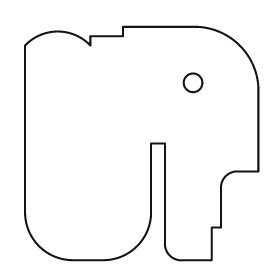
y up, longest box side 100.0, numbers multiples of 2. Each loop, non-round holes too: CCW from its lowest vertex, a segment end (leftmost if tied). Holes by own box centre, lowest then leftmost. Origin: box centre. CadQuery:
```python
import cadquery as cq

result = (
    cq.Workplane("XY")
    .moveTo(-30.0, -50.0)
    .lineTo(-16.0, -50.0)
    .threePointArc((-2.0, -44.0), (4.0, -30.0))
    .lineTo(4.0, 0.0)
    .lineTo(10.0, 0.0)
    .lineTo(10.0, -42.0)
    .threePointArc((12.0, -48.0), (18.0, -50.0))
    .lineTo(30.0, -50.0)
    .lineTo(30.0, -36.0)
    .lineTo(34.0, -36.0)
    .lineTo(34.0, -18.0)
    .threePointArc((36.0, -14.0), (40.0, -12.0))
    .lineTo(50.0, -12.0)
    .lineTo(50.0, 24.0)
    .threePointArc((42.0, 42.0), (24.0, 50.0))
    .lineTo(-8.0, 50.0)
    .lineTo(-8.0, 46.0)
    .lineTo(-22.0, 46.0)
    .lineTo(-22.0, 42.0)
    .threePointArc((-36.0, 48.0), (-50.0, 42.0))
    .lineTo(-50.0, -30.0)
    .threePointArc((-44.0, -44.0), (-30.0, -50.0))
    .close()
    .moveTo(22.0, 26.0)
    .circle(4.0)
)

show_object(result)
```